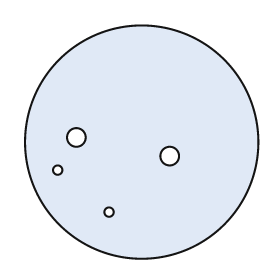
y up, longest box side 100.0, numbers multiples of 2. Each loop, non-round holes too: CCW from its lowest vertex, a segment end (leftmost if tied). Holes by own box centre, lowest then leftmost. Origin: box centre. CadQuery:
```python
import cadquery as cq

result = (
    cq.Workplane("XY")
    .moveTo(0.0, 0.0)
    .circle(50.0)
    .moveTo(-14.0, -30.0)
    .circle(2.0)
    .moveTo(-36.0, -12.0)
    .circle(2.0)
    .moveTo(12.0, -6.0)
    .circle(4.0)
    .moveTo(-28.0, 2.0)
    .circle(4.0)
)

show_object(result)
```